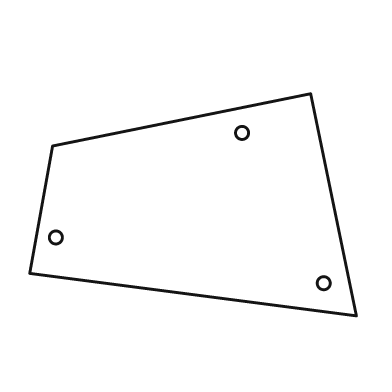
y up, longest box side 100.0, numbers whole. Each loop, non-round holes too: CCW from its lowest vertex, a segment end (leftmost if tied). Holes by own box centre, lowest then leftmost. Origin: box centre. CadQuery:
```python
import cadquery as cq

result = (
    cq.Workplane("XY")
    .moveTo(50.0, -34.0)
    .lineTo(36.0, 34.0)
    .lineTo(-43.0, 18.0)
    .lineTo(-50.0, -21.0)
    .close()
    .moveTo(40.0, -24.0)
    .circle(2.0)
    .moveTo(-42.0, -10.0)
    .circle(2.0)
    .moveTo(15.0, 22.0)
    .circle(2.0)
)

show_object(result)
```